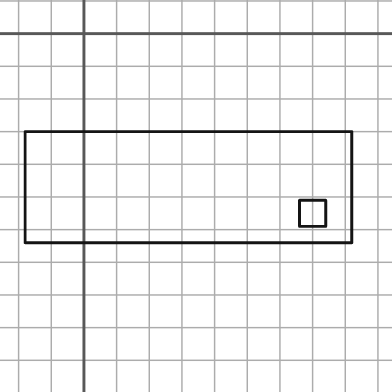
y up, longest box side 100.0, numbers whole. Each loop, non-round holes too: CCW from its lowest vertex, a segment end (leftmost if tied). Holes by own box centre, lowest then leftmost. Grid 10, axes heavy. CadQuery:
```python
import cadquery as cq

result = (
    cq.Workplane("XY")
    .moveTo(-18.0, -64.0)
    .lineTo(82.0, -64.0)
    .lineTo(82.0, -30.0)
    .lineTo(-18.0, -30.0)
    .close()
    .moveTo(66.0, -59.0)
    .lineTo(74.0, -59.0)
    .lineTo(74.0, -51.0)
    .lineTo(66.0, -51.0)
    .close()
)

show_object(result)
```